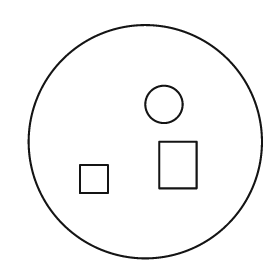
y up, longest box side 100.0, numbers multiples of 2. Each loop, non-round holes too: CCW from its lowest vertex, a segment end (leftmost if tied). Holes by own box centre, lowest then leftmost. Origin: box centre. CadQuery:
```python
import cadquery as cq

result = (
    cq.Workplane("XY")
    .moveTo(0.0, 0.0)
    .circle(50.0)
    .moveTo(-28.0, -22.0)
    .lineTo(-16.0, -22.0)
    .lineTo(-16.0, -10.0)
    .lineTo(-28.0, -10.0)
    .close()
    .moveTo(6.0, -20.0)
    .lineTo(22.0, -20.0)
    .lineTo(22.0, 0.0)
    .lineTo(6.0, 0.0)
    .close()
    .moveTo(8.0, 16.0)
    .circle(8.0)
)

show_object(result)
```